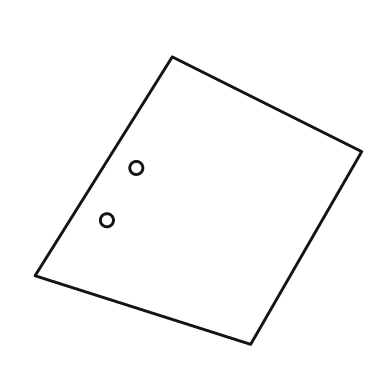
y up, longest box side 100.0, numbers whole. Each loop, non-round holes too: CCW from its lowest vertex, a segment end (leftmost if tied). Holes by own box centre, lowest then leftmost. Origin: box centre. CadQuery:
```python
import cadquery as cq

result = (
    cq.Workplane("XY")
    .moveTo(16.0, -44.0)
    .lineTo(50.0, 15.0)
    .lineTo(-8.0, 44.0)
    .lineTo(-50.0, -23.0)
    .close()
    .moveTo(-28.0, -6.0)
    .circle(2.0)
    .moveTo(-19.0, 10.0)
    .circle(2.0)
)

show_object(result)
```